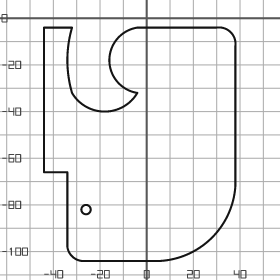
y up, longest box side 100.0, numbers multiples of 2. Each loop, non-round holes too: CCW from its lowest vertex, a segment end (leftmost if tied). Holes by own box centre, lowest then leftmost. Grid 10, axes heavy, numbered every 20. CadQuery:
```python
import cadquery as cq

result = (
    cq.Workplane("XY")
    .moveTo(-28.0, -104.0)
    .lineTo(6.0, -104.0)
    .threePointArc((28.0, -94.0), (38.0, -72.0))
    .lineTo(38.0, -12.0)
    .threePointArc((36.0, -6.0), (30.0, -4.0))
    .lineTo(-4.0, -4.0)
    .threePointArc((-16.0, -18.0), (-4.0, -32.0))
    .threePointArc((-18.0, -40.0), (-32.0, -32.0))
    .threePointArc((-34.0, -18.0), (-32.0, -4.0))
    .lineTo(-44.0, -4.0)
    .lineTo(-44.0, -66.0)
    .lineTo(-34.0, -66.0)
    .lineTo(-34.0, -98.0)
    .threePointArc((-32.0, -102.0), (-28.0, -104.0))
    .close()
    .moveTo(-26.0, -82.0)
    .circle(2.0)
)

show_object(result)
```